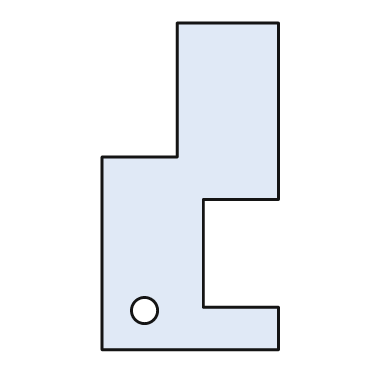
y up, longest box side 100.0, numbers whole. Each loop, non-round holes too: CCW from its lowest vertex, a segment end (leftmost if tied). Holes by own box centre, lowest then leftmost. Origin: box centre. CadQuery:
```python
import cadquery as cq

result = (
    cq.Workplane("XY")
    .moveTo(-27.0, -50.0)
    .lineTo(27.0, -50.0)
    .lineTo(27.0, -37.0)
    .lineTo(4.0, -37.0)
    .lineTo(4.0, -4.0)
    .lineTo(27.0, -4.0)
    .lineTo(27.0, 50.0)
    .lineTo(-4.0, 50.0)
    .lineTo(-4.0, 9.0)
    .lineTo(-27.0, 9.0)
    .close()
    .moveTo(-14.0, -38.0)
    .circle(4.0)
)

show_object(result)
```